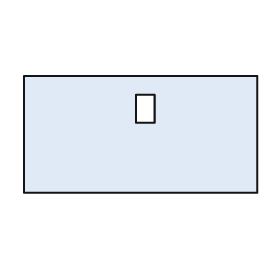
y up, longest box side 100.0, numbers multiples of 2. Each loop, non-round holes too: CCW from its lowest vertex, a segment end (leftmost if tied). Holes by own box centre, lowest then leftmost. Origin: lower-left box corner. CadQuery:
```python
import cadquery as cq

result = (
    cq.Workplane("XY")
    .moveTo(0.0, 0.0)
    .lineTo(100.0, 0.0)
    .lineTo(100.0, 50.0)
    .lineTo(0.0, 50.0)
    .close()
    .moveTo(48.0, 30.0)
    .lineTo(56.0, 30.0)
    .lineTo(56.0, 42.0)
    .lineTo(48.0, 42.0)
    .close()
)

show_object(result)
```